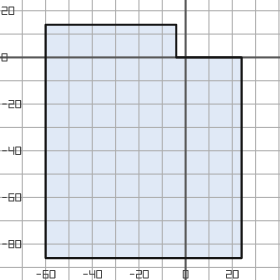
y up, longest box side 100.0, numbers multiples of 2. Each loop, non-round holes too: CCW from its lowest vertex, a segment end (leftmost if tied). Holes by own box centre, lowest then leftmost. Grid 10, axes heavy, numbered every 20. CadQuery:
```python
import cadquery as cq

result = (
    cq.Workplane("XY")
    .moveTo(-60.0, -86.0)
    .lineTo(24.0, -86.0)
    .lineTo(24.0, 0.0)
    .lineTo(-4.0, 0.0)
    .lineTo(-4.0, 14.0)
    .lineTo(-60.0, 14.0)
    .close()
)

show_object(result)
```